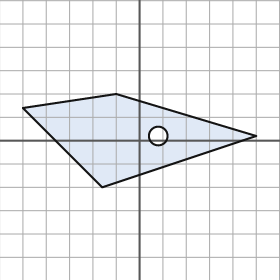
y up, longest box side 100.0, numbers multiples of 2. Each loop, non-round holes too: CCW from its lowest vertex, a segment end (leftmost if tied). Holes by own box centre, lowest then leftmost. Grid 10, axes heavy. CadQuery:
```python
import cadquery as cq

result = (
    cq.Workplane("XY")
    .moveTo(-16.0, -20.0)
    .lineTo(50.0, 2.0)
    .lineTo(-10.0, 20.0)
    .lineTo(-50.0, 14.0)
    .close()
    .moveTo(8.0, 2.0)
    .circle(4.0)
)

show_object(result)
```